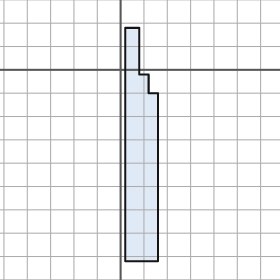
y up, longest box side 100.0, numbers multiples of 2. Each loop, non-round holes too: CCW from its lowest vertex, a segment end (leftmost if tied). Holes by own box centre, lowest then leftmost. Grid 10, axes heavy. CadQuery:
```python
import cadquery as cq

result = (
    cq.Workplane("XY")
    .moveTo(2.0, -82.0)
    .lineTo(16.0, -82.0)
    .lineTo(16.0, -10.0)
    .lineTo(12.0, -10.0)
    .lineTo(12.0, -2.0)
    .lineTo(8.0, -2.0)
    .lineTo(8.0, 18.0)
    .lineTo(2.0, 18.0)
    .close()
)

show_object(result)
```